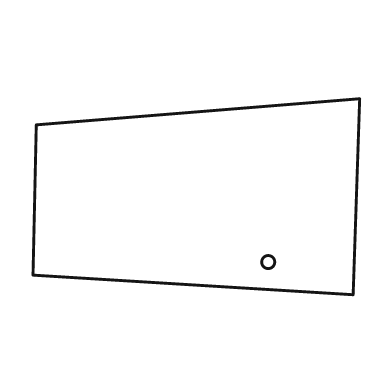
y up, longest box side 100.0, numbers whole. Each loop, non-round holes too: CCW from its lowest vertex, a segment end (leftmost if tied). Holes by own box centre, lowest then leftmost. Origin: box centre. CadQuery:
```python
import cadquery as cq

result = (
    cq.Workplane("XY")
    .moveTo(48.0, -30.0)
    .lineTo(50.0, 30.0)
    .lineTo(-49.0, 22.0)
    .lineTo(-50.0, -24.0)
    .close()
    .moveTo(22.0, -20.0)
    .circle(2.0)
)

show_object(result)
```